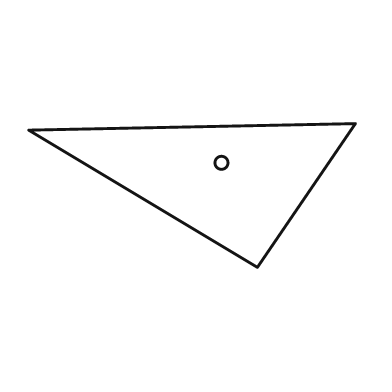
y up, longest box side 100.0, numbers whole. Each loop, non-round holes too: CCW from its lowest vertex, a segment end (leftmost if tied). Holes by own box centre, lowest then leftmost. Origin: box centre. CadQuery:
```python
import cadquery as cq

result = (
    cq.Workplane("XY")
    .moveTo(20.0, -22.0)
    .lineTo(50.0, 22.0)
    .lineTo(-50.0, 20.0)
    .close()
    .moveTo(9.0, 10.0)
    .circle(2.0)
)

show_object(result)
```